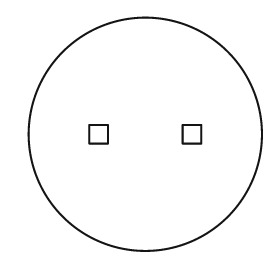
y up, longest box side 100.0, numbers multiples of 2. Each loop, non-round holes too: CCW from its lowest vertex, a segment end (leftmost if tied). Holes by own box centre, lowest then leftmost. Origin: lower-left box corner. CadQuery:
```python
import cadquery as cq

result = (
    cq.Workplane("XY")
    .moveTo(50.0, 50.0)
    .circle(50.0)
    .moveTo(26.0, 46.0)
    .lineTo(34.0, 46.0)
    .lineTo(34.0, 54.0)
    .lineTo(26.0, 54.0)
    .close()
    .moveTo(66.0, 46.0)
    .lineTo(74.0, 46.0)
    .lineTo(74.0, 54.0)
    .lineTo(66.0, 54.0)
    .close()
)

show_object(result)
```